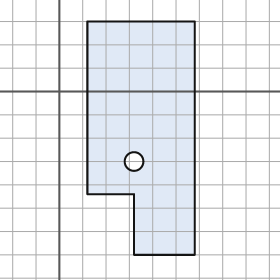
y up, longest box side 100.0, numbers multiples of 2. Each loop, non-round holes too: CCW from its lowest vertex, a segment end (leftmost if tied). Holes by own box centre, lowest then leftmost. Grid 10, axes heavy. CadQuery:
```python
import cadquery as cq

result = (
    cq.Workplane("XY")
    .moveTo(32.0, -70.0)
    .lineTo(58.0, -70.0)
    .lineTo(58.0, 30.0)
    .lineTo(12.0, 30.0)
    .lineTo(12.0, -44.0)
    .lineTo(32.0, -44.0)
    .close()
    .moveTo(32.0, -30.0)
    .circle(4.0)
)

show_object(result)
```